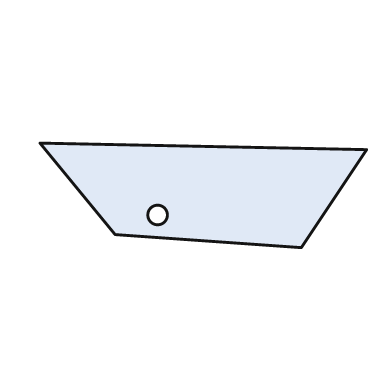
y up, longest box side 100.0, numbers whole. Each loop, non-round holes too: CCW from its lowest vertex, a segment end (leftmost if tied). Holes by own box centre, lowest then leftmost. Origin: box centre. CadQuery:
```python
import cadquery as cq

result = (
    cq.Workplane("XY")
    .moveTo(30.0, -16.0)
    .lineTo(50.0, 14.0)
    .lineTo(-50.0, 16.0)
    .lineTo(-27.0, -12.0)
    .close()
    .moveTo(-14.0, -6.0)
    .circle(3.0)
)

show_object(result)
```